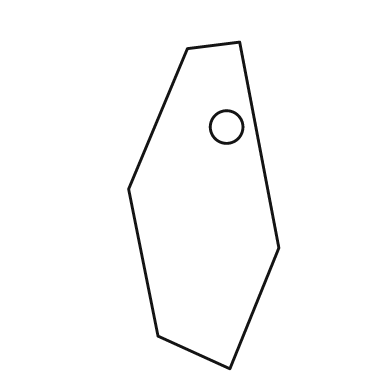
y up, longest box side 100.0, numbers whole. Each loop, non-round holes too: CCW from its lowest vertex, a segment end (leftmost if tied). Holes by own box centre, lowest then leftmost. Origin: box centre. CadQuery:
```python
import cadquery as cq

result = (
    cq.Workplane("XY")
    .moveTo(8.0, -50.0)
    .lineTo(23.0, -13.0)
    .lineTo(11.0, 50.0)
    .lineTo(-5.0, 48.0)
    .lineTo(-23.0, 5.0)
    .lineTo(-14.0, -40.0)
    .close()
    .moveTo(7.0, 24.0)
    .circle(5.0)
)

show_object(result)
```